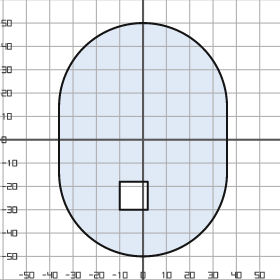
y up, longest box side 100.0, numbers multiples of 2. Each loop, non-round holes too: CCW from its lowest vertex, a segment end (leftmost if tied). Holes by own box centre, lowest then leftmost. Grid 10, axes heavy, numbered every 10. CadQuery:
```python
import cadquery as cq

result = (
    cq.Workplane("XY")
    .moveTo(-36.0, -14.0)
    .threePointArc((0.0, -50.0), (36.0, -14.0))
    .lineTo(36.0, 14.0)
    .threePointArc((0.0, 50.0), (-36.0, 14.0))
    .close()
    .moveTo(-10.0, -30.0)
    .lineTo(2.0, -30.0)
    .lineTo(2.0, -18.0)
    .lineTo(-10.0, -18.0)
    .close()
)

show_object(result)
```